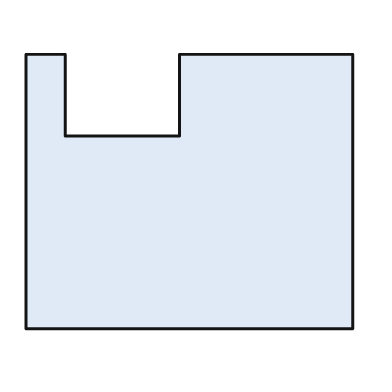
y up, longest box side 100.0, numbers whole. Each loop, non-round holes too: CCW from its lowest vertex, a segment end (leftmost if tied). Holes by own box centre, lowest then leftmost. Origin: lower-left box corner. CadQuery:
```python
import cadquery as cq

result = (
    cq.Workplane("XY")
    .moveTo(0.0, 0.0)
    .lineTo(100.0, 0.0)
    .lineTo(100.0, 84.0)
    .lineTo(47.0, 84.0)
    .lineTo(47.0, 59.0)
    .lineTo(12.0, 59.0)
    .lineTo(12.0, 84.0)
    .lineTo(0.0, 84.0)
    .close()
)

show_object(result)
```